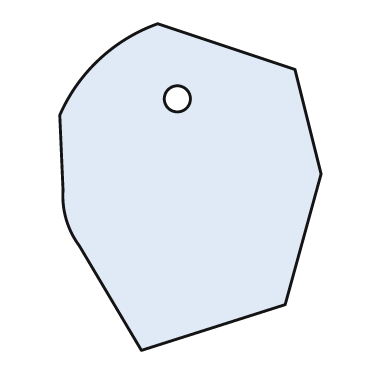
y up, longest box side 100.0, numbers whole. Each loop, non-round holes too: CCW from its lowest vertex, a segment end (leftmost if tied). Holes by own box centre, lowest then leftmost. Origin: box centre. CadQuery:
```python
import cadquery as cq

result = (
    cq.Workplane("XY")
    .moveTo(-15.0, -50.0)
    .lineTo(29.0, -36.0)
    .lineTo(40.0, 4.0)
    .lineTo(32.0, 36.0)
    .lineTo(-10.0, 50.0)
    .threePointArc((-28.0, 39.0), (-40.0, 22.0))
    .lineTo(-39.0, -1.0)
    .threePointArc((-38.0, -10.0), (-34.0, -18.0))
    .close()
    .moveTo(-4.0, 27.0)
    .circle(4.0)
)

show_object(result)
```